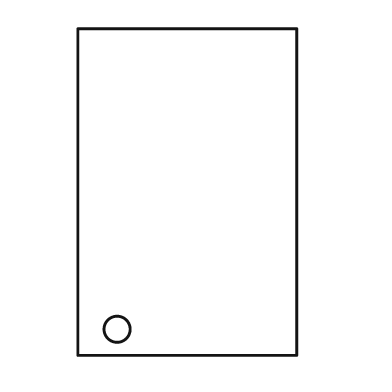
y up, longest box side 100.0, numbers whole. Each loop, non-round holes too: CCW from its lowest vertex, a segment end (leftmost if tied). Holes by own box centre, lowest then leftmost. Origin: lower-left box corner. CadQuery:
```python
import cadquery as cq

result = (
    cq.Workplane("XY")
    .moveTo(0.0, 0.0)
    .lineTo(67.0, 0.0)
    .lineTo(67.0, 100.0)
    .lineTo(0.0, 100.0)
    .close()
    .moveTo(12.0, 8.0)
    .circle(4.0)
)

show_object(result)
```